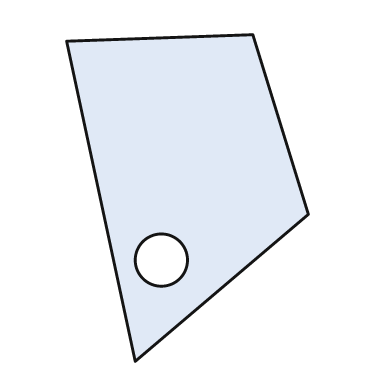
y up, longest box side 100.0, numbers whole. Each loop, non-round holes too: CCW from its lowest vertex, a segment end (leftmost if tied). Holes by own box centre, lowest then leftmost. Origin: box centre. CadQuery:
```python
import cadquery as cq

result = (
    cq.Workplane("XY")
    .moveTo(-16.0, -50.0)
    .lineTo(37.0, -5.0)
    .lineTo(20.0, 50.0)
    .lineTo(-37.0, 48.0)
    .close()
    .moveTo(-8.0, -19.0)
    .circle(8.0)
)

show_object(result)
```